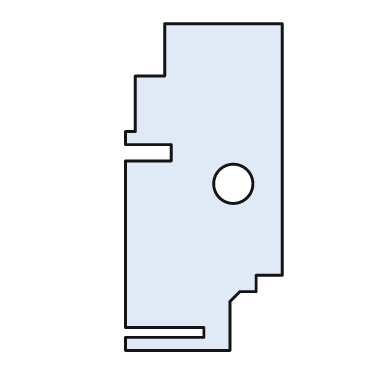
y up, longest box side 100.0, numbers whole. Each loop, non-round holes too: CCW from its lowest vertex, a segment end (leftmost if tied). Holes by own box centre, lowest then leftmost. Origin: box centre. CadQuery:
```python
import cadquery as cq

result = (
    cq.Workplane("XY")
    .moveTo(-24.0, -50.0)
    .lineTo(8.0, -50.0)
    .lineTo(8.0, -35.0)
    .lineTo(11.0, -32.0)
    .lineTo(16.0, -32.0)
    .lineTo(16.0, -27.0)
    .lineTo(24.0, -27.0)
    .lineTo(24.0, 50.0)
    .lineTo(-12.0, 50.0)
    .lineTo(-12.0, 34.0)
    .lineTo(-21.0, 34.0)
    .lineTo(-21.0, 17.0)
    .lineTo(-24.0, 17.0)
    .lineTo(-24.0, 13.0)
    .lineTo(-10.0, 13.0)
    .lineTo(-10.0, 8.0)
    .lineTo(-24.0, 8.0)
    .lineTo(-24.0, -43.0)
    .lineTo(0.0, -43.0)
    .lineTo(0.0, -46.0)
    .lineTo(-24.0, -46.0)
    .close()
    .moveTo(9.0, 1.0)
    .circle(6.0)
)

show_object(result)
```